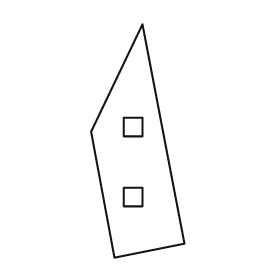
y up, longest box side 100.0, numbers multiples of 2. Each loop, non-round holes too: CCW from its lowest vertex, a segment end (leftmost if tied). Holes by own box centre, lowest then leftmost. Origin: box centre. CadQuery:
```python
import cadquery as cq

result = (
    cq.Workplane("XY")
    .moveTo(-10.0, -50.0)
    .lineTo(20.0, -44.0)
    .lineTo(2.0, 50.0)
    .lineTo(-20.0, 4.0)
    .close()
    .moveTo(-6.0, -28.0)
    .lineTo(2.0, -28.0)
    .lineTo(2.0, -20.0)
    .lineTo(-6.0, -20.0)
    .close()
    .moveTo(-6.0, 2.0)
    .lineTo(2.0, 2.0)
    .lineTo(2.0, 10.0)
    .lineTo(-6.0, 10.0)
    .close()
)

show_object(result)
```